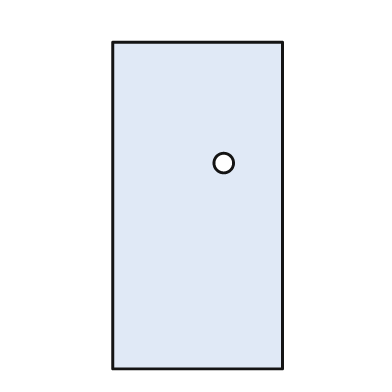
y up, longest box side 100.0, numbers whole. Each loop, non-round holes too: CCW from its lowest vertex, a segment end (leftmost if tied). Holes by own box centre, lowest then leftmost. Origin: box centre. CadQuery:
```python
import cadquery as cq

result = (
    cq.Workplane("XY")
    .moveTo(-26.0, -50.0)
    .lineTo(26.0, -50.0)
    .lineTo(26.0, 50.0)
    .lineTo(-26.0, 50.0)
    .close()
    .moveTo(8.0, 13.0)
    .circle(3.0)
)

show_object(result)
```